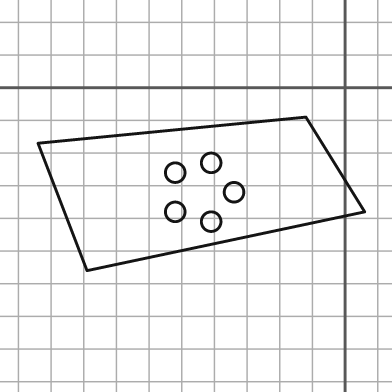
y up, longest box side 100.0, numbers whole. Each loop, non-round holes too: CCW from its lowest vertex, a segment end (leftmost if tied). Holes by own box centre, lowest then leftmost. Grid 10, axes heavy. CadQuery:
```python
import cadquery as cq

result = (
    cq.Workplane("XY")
    .moveTo(-79.0, -56.0)
    .lineTo(6.0, -38.0)
    .lineTo(-12.0, -9.0)
    .lineTo(-94.0, -17.0)
    .close()
    .moveTo(-41.0, -41.0)
    .circle(3.0)
    .moveTo(-52.0, -38.0)
    .circle(3.0)
    .moveTo(-34.0, -32.0)
    .circle(3.0)
    .moveTo(-52.0, -26.0)
    .circle(3.0)
    .moveTo(-41.0, -23.0)
    .circle(3.0)
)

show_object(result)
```